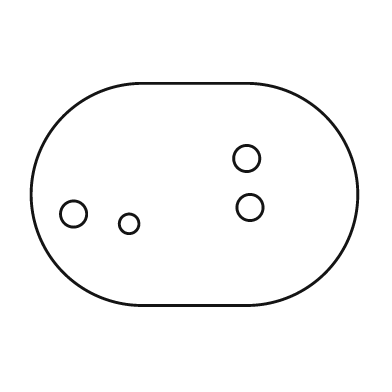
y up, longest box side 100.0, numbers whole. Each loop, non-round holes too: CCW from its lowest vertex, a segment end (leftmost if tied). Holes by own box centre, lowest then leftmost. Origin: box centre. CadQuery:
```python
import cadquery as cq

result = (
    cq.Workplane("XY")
    .moveTo(-16.0, -34.0)
    .lineTo(16.0, -34.0)
    .threePointArc((50.0, 0.0), (16.0, 34.0))
    .lineTo(-16.0, 34.0)
    .threePointArc((-50.0, 0.0), (-16.0, -34.0))
    .close()
    .moveTo(-20.0, -9.0)
    .circle(3.0)
    .moveTo(-37.0, -6.0)
    .circle(4.0)
    .moveTo(17.0, -4.0)
    .circle(4.0)
    .moveTo(16.0, 11.0)
    .circle(4.0)
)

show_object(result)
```